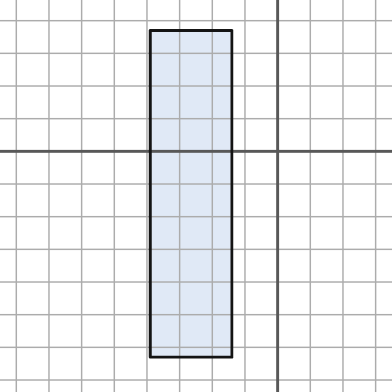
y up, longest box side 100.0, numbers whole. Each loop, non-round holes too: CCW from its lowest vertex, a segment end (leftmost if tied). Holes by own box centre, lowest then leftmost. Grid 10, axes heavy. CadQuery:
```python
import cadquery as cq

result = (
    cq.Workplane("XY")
    .moveTo(-39.0, -63.0)
    .lineTo(-14.0, -63.0)
    .lineTo(-14.0, 37.0)
    .lineTo(-39.0, 37.0)
    .close()
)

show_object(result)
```